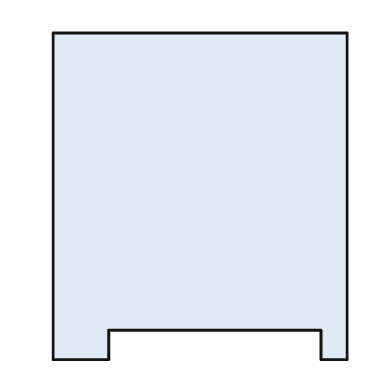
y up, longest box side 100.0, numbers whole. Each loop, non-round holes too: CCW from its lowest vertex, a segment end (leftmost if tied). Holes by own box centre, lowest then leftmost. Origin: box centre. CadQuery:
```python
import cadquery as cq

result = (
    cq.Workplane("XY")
    .moveTo(-45.0, -50.0)
    .lineTo(-28.0, -50.0)
    .lineTo(-28.0, -41.0)
    .lineTo(37.0, -41.0)
    .lineTo(37.0, -50.0)
    .lineTo(45.0, -50.0)
    .lineTo(45.0, 50.0)
    .lineTo(-45.0, 50.0)
    .close()
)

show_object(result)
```